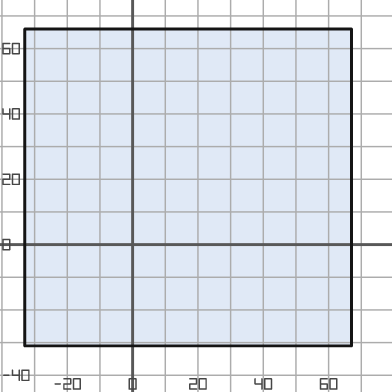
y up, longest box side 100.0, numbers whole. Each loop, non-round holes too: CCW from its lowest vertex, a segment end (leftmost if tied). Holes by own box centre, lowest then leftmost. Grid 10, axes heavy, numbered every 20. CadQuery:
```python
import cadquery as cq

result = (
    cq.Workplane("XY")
    .moveTo(-33.0, -31.0)
    .lineTo(67.0, -31.0)
    .lineTo(67.0, 66.0)
    .lineTo(-33.0, 66.0)
    .close()
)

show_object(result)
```